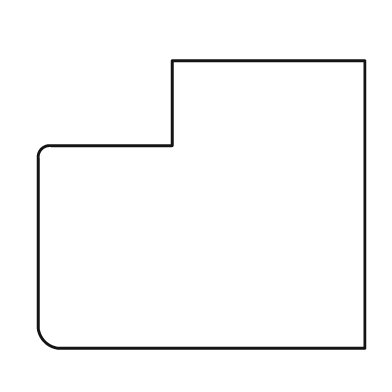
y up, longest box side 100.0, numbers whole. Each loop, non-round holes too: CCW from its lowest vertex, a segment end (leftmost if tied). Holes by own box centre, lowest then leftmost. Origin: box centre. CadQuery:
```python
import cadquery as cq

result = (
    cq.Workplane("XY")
    .moveTo(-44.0, -44.0)
    .lineTo(50.0, -44.0)
    .lineTo(50.0, 44.0)
    .lineTo(-9.0, 44.0)
    .lineTo(-9.0, 18.0)
    .lineTo(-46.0, 18.0)
    .threePointArc((-49.0, 17.0), (-50.0, 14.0))
    .lineTo(-50.0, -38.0)
    .threePointArc((-48.0, -42.0), (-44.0, -44.0))
    .close()
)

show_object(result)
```